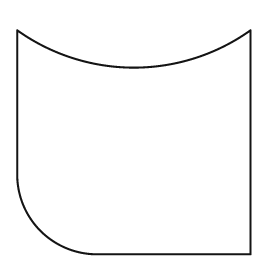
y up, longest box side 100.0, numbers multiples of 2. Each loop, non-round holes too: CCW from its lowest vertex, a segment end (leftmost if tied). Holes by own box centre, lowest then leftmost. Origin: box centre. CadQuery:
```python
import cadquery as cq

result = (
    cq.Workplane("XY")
    .moveTo(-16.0, -48.0)
    .lineTo(50.0, -48.0)
    .lineTo(50.0, 48.0)
    .threePointArc((0.0, 32.0), (-50.0, 48.0))
    .lineTo(-50.0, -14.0)
    .threePointArc((-40.0, -38.0), (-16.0, -48.0))
    .close()
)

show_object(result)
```